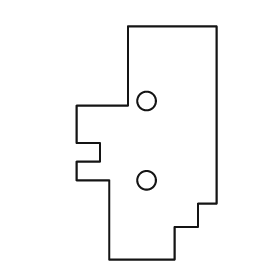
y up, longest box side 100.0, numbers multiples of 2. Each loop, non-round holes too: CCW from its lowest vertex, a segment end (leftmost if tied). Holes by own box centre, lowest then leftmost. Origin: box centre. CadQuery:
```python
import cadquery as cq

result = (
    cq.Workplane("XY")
    .moveTo(-16.0, -50.0)
    .lineTo(12.0, -50.0)
    .lineTo(12.0, -36.0)
    .lineTo(22.0, -36.0)
    .lineTo(22.0, -26.0)
    .lineTo(30.0, -26.0)
    .lineTo(30.0, 50.0)
    .lineTo(-8.0, 50.0)
    .lineTo(-8.0, 16.0)
    .lineTo(-30.0, 16.0)
    .lineTo(-30.0, 0.0)
    .lineTo(-20.0, 0.0)
    .lineTo(-20.0, -8.0)
    .lineTo(-30.0, -8.0)
    .lineTo(-30.0, -16.0)
    .lineTo(-16.0, -16.0)
    .close()
    .moveTo(0.0, -16.0)
    .circle(4.0)
    .moveTo(0.0, 18.0)
    .circle(4.0)
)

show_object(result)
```